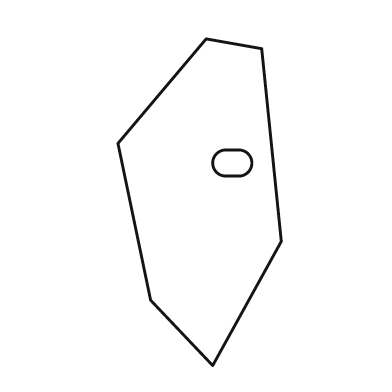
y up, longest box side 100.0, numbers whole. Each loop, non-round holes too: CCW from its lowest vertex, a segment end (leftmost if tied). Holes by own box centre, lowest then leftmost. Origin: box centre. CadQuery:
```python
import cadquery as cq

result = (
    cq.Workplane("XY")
    .moveTo(4.0, -50.0)
    .lineTo(25.0, -12.0)
    .lineTo(19.0, 47.0)
    .lineTo(2.0, 50.0)
    .lineTo(-25.0, 18.0)
    .lineTo(-15.0, -30.0)
    .close()
    .moveTo(8.0, 8.0)
    .lineTo(12.0, 8.0)
    .threePointArc((16.0, 12.0), (12.0, 16.0))
    .lineTo(8.0, 16.0)
    .threePointArc((4.0, 12.0), (8.0, 8.0))
    .close()
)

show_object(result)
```